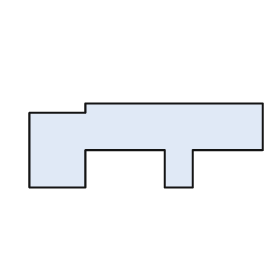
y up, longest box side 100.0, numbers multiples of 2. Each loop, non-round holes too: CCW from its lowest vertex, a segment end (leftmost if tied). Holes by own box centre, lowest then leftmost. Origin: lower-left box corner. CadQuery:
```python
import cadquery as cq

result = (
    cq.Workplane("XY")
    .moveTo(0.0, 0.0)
    .lineTo(24.0, 0.0)
    .lineTo(24.0, 16.0)
    .lineTo(58.0, 16.0)
    .lineTo(58.0, 0.0)
    .lineTo(70.0, 0.0)
    .lineTo(70.0, 16.0)
    .lineTo(100.0, 16.0)
    .lineTo(100.0, 36.0)
    .lineTo(24.0, 36.0)
    .lineTo(24.0, 32.0)
    .lineTo(0.0, 32.0)
    .close()
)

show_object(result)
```